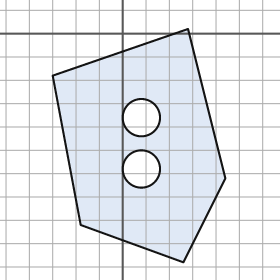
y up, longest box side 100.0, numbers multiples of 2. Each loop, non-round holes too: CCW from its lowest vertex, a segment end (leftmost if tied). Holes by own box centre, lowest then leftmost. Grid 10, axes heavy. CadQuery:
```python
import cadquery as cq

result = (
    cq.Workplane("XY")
    .moveTo(26.0, -98.0)
    .lineTo(44.0, -62.0)
    .lineTo(28.0, 2.0)
    .lineTo(-30.0, -18.0)
    .lineTo(-18.0, -82.0)
    .close()
    .moveTo(8.0, -58.0)
    .circle(8.0)
    .moveTo(8.0, -36.0)
    .circle(8.0)
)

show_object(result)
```